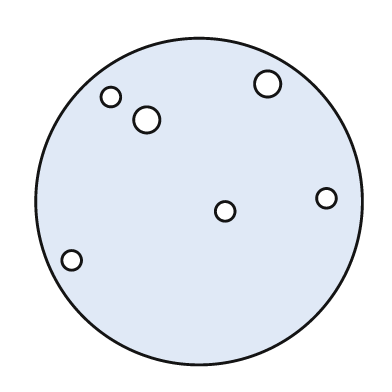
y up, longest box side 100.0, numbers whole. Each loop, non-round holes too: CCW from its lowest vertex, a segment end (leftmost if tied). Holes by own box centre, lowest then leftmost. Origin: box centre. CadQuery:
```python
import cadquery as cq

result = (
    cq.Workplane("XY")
    .moveTo(0.0, 0.0)
    .circle(50.0)
    .moveTo(-39.0, -18.0)
    .circle(3.0)
    .moveTo(8.0, -3.0)
    .circle(3.0)
    .moveTo(39.0, 1.0)
    .circle(3.0)
    .moveTo(-16.0, 25.0)
    .circle(4.0)
    .moveTo(-27.0, 32.0)
    .circle(3.0)
    .moveTo(21.0, 36.0)
    .circle(4.0)
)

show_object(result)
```